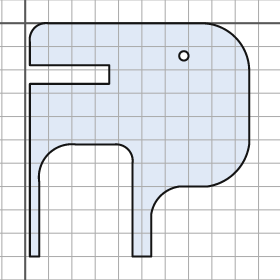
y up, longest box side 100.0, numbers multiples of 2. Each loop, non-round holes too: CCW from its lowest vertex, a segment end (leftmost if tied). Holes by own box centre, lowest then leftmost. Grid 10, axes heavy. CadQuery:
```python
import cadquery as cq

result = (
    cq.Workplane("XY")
    .moveTo(2.0, -100.0)
    .lineTo(6.0, -100.0)
    .lineTo(6.0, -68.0)
    .threePointArc((10.0, -56.0), (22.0, -52.0))
    .lineTo(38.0, -52.0)
    .threePointArc((44.0, -54.0), (46.0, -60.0))
    .lineTo(46.0, -100.0)
    .lineTo(54.0, -100.0)
    .lineTo(54.0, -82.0)
    .threePointArc((58.0, -74.0), (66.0, -70.0))
    .lineTo(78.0, -70.0)
    .threePointArc((90.0, -64.0), (96.0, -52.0))
    .lineTo(96.0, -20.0)
    .threePointArc((90.0, -6.0), (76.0, 0.0))
    .lineTo(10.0, 0.0)
    .threePointArc((4.0, -2.0), (2.0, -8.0))
    .lineTo(2.0, -18.0)
    .lineTo(36.0, -18.0)
    .lineTo(36.0, -26.0)
    .lineTo(2.0, -26.0)
    .close()
    .moveTo(68.0, -14.0)
    .circle(2.0)
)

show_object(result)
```